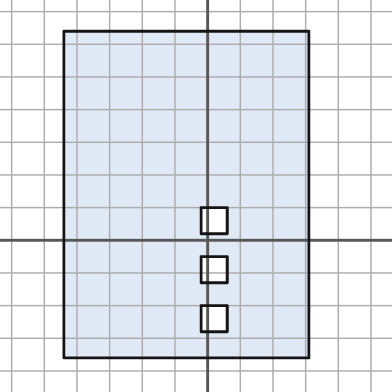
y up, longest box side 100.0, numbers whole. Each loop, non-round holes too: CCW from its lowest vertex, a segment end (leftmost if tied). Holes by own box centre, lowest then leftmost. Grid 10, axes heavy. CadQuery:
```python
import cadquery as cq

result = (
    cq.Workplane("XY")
    .moveTo(-44.0, -36.0)
    .lineTo(31.0, -36.0)
    .lineTo(31.0, 64.0)
    .lineTo(-44.0, 64.0)
    .close()
    .moveTo(-2.0, -28.0)
    .lineTo(6.0, -28.0)
    .lineTo(6.0, -20.0)
    .lineTo(-2.0, -20.0)
    .close()
    .moveTo(-2.0, -13.0)
    .lineTo(6.0, -13.0)
    .lineTo(6.0, -5.0)
    .lineTo(-2.0, -5.0)
    .close()
    .moveTo(-2.0, 2.0)
    .lineTo(6.0, 2.0)
    .lineTo(6.0, 10.0)
    .lineTo(-2.0, 10.0)
    .close()
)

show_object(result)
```